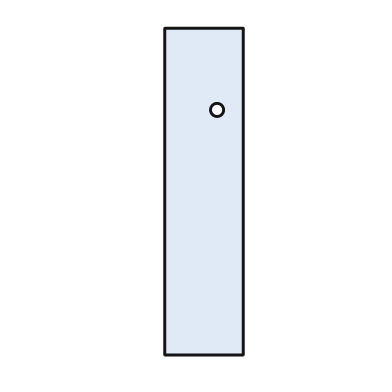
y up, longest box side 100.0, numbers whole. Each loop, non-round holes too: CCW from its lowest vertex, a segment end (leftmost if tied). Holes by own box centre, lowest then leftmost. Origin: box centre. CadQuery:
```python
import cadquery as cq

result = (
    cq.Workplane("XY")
    .moveTo(-12.0, -50.0)
    .lineTo(12.0, -50.0)
    .lineTo(12.0, 50.0)
    .lineTo(-12.0, 50.0)
    .close()
    .moveTo(4.0, 25.0)
    .circle(2.0)
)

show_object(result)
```